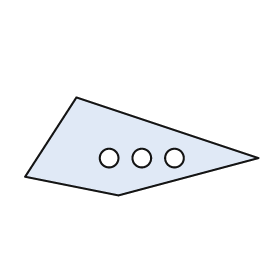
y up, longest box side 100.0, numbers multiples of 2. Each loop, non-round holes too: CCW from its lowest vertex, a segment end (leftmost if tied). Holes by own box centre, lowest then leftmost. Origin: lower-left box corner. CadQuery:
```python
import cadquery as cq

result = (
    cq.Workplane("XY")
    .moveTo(40.0, 0.0)
    .lineTo(100.0, 16.0)
    .lineTo(22.0, 42.0)
    .lineTo(0.0, 8.0)
    .close()
    .moveTo(36.0, 16.0)
    .circle(4.0)
    .moveTo(50.0, 16.0)
    .circle(4.0)
    .moveTo(64.0, 16.0)
    .circle(4.0)
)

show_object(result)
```